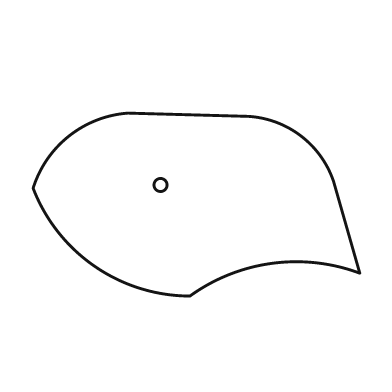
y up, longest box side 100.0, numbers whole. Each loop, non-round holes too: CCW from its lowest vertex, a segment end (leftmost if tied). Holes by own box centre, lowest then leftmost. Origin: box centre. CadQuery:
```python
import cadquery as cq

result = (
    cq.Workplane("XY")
    .moveTo(-2.0, -28.0)
    .threePointArc((23.0, -18.0), (50.0, -21.0))
    .lineTo(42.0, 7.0)
    .threePointArc((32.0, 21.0), (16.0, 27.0))
    .lineTo(-21.0, 28.0)
    .threePointArc((-39.0, 21.0), (-50.0, 5.0))
    .threePointArc((-31.0, -19.0), (-2.0, -28.0))
    .close()
    .moveTo(-11.0, 6.0)
    .circle(2.0)
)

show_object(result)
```